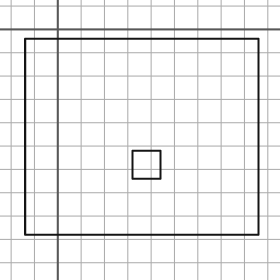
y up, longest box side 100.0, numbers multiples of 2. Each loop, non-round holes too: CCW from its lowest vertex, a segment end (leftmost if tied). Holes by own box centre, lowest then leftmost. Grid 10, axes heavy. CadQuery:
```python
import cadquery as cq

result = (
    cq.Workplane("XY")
    .moveTo(-14.0, -88.0)
    .lineTo(86.0, -88.0)
    .lineTo(86.0, -4.0)
    .lineTo(-14.0, -4.0)
    .close()
    .moveTo(32.0, -64.0)
    .lineTo(44.0, -64.0)
    .lineTo(44.0, -52.0)
    .lineTo(32.0, -52.0)
    .close()
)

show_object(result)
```